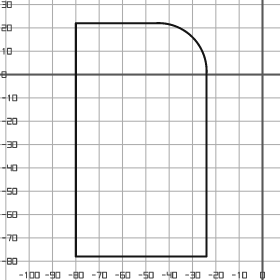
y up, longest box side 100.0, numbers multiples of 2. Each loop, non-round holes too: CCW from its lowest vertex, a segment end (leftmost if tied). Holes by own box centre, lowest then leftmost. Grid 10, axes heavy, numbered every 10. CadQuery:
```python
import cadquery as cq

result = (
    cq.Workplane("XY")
    .moveTo(-80.0, -78.0)
    .lineTo(-24.0, -78.0)
    .lineTo(-24.0, 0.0)
    .threePointArc((-30.0, 16.0), (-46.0, 22.0))
    .lineTo(-80.0, 22.0)
    .close()
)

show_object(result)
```